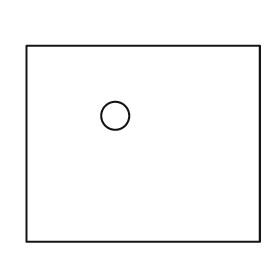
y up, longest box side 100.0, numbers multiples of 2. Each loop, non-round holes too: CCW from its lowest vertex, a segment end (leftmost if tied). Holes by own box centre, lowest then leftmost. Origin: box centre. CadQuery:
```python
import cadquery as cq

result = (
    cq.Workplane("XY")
    .moveTo(-50.0, -42.0)
    .lineTo(50.0, -42.0)
    .lineTo(50.0, 42.0)
    .lineTo(-50.0, 42.0)
    .close()
    .moveTo(-12.0, 12.0)
    .circle(6.0)
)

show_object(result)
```